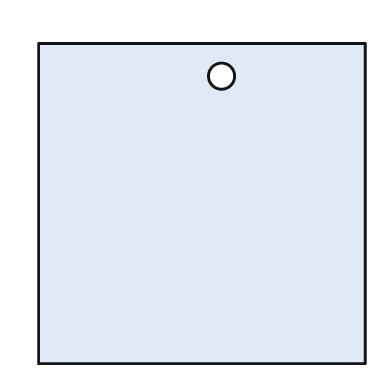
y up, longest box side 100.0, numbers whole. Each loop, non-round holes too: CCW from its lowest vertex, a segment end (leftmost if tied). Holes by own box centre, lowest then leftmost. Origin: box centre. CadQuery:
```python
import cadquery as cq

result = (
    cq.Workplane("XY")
    .moveTo(-50.0, -49.0)
    .lineTo(50.0, -49.0)
    .lineTo(50.0, 49.0)
    .lineTo(-50.0, 49.0)
    .close()
    .moveTo(6.0, 39.0)
    .circle(4.0)
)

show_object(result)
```